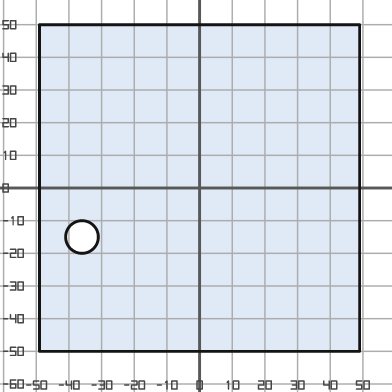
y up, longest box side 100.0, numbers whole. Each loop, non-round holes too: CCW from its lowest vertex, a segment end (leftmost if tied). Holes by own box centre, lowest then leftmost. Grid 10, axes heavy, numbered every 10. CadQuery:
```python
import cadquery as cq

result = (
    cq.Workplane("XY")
    .moveTo(-49.0, -50.0)
    .lineTo(49.0, -50.0)
    .lineTo(49.0, 50.0)
    .lineTo(-49.0, 50.0)
    .close()
    .moveTo(-36.0, -15.0)
    .circle(5.0)
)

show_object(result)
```